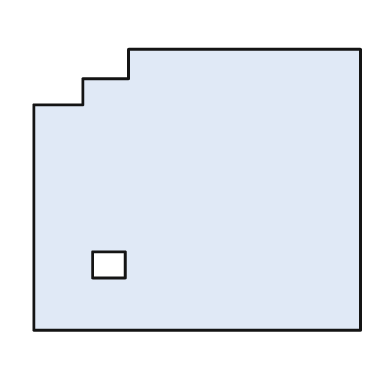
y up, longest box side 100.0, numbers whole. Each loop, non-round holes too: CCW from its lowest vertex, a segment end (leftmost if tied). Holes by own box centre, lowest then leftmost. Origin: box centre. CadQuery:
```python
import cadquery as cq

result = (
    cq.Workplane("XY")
    .moveTo(-50.0, -43.0)
    .lineTo(50.0, -43.0)
    .lineTo(50.0, 43.0)
    .lineTo(-21.0, 43.0)
    .lineTo(-21.0, 34.0)
    .lineTo(-35.0, 34.0)
    .lineTo(-35.0, 26.0)
    .lineTo(-50.0, 26.0)
    .close()
    .moveTo(-32.0, -27.0)
    .lineTo(-22.0, -27.0)
    .lineTo(-22.0, -19.0)
    .lineTo(-32.0, -19.0)
    .close()
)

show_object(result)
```